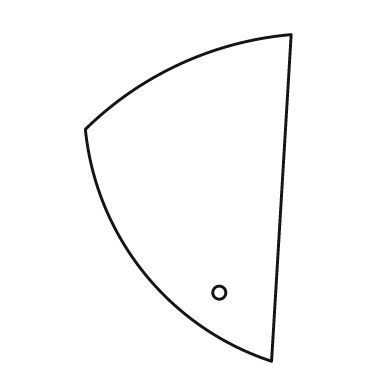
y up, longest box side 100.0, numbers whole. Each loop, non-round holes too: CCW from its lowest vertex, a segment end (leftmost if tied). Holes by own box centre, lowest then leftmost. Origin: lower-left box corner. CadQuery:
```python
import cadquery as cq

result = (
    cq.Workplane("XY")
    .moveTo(57.0, 0.0)
    .lineTo(63.0, 100.0)
    .threePointArc((29.0, 91.0), (0.0, 71.0))
    .threePointArc((18.0, 27.0), (57.0, 0.0))
    .close()
    .moveTo(41.0, 21.0)
    .circle(2.0)
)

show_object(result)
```